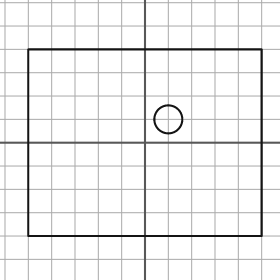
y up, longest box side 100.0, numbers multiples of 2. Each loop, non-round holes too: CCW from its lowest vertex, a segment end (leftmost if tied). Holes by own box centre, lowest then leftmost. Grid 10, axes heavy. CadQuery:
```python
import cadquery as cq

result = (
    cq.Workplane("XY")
    .moveTo(-50.0, -40.0)
    .lineTo(50.0, -40.0)
    .lineTo(50.0, 40.0)
    .lineTo(-50.0, 40.0)
    .close()
    .moveTo(10.0, 10.0)
    .circle(6.0)
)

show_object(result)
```